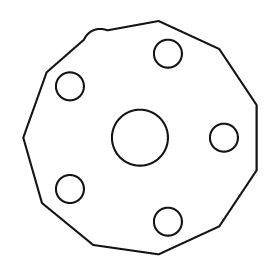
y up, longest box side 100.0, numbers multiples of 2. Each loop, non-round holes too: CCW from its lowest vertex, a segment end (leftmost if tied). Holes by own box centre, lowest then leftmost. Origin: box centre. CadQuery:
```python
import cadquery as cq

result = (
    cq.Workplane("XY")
    .moveTo(8.0, -50.0)
    .lineTo(34.0, -38.0)
    .lineTo(50.0, -14.0)
    .lineTo(50.0, 14.0)
    .lineTo(34.0, 38.0)
    .lineTo(8.0, 50.0)
    .lineTo(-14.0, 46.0)
    .threePointArc((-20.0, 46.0), (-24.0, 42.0))
    .lineTo(-40.0, 28.0)
    .lineTo(-50.0, 0.0)
    .lineTo(-42.0, -28.0)
    .lineTo(-20.0, -46.0)
    .close()
    .moveTo(12.0, -36.0)
    .circle(6.0)
    .moveTo(-30.0, -22.0)
    .circle(6.0)
    .moveTo(0.0, 0.0)
    .circle(12.0)
    .moveTo(36.0, 0.0)
    .circle(6.0)
    .moveTo(-30.0, 22.0)
    .circle(6.0)
    .moveTo(12.0, 36.0)
    .circle(6.0)
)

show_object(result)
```